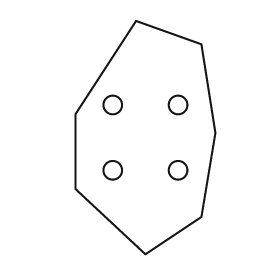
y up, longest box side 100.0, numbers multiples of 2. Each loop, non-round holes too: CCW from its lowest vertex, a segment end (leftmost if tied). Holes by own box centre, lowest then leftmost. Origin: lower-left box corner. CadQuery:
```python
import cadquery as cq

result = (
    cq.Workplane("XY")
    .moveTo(30.0, 0.0)
    .lineTo(54.0, 16.0)
    .lineTo(60.0, 52.0)
    .lineTo(54.0, 90.0)
    .lineTo(26.0, 100.0)
    .lineTo(0.0, 60.0)
    .lineTo(0.0, 28.0)
    .close()
    .moveTo(16.0, 36.0)
    .circle(4.0)
    .moveTo(44.0, 36.0)
    .circle(4.0)
    .moveTo(16.0, 64.0)
    .circle(4.0)
    .moveTo(44.0, 64.0)
    .circle(4.0)
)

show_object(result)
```